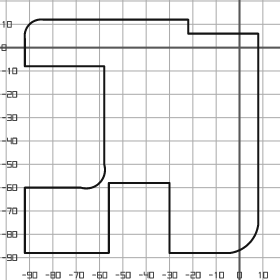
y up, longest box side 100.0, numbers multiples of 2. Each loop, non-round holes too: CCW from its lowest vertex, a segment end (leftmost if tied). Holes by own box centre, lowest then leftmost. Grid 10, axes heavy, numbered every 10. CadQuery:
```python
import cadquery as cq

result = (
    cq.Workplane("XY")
    .moveTo(-92.0, -88.0)
    .lineTo(-56.0, -88.0)
    .lineTo(-56.0, -58.0)
    .lineTo(-30.0, -58.0)
    .lineTo(-30.0, -88.0)
    .lineTo(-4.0, -88.0)
    .threePointArc((4.0, -84.0), (8.0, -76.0))
    .lineTo(8.0, 6.0)
    .lineTo(-22.0, 6.0)
    .lineTo(-22.0, 12.0)
    .lineTo(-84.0, 12.0)
    .threePointArc((-90.0, 10.0), (-92.0, 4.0))
    .lineTo(-92.0, -8.0)
    .lineTo(-58.0, -8.0)
    .lineTo(-58.0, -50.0)
    .threePointArc((-60.0, -58.0), (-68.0, -60.0))
    .lineTo(-92.0, -60.0)
    .close()
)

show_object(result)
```